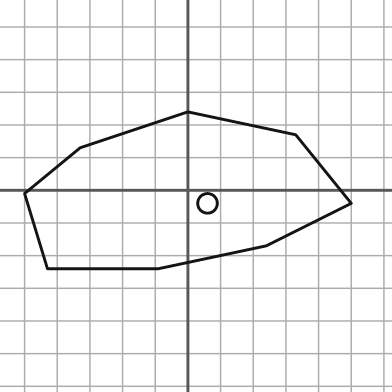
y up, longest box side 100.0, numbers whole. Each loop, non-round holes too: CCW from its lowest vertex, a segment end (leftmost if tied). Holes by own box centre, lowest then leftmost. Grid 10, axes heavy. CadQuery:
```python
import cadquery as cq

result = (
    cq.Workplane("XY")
    .moveTo(-43.0, -24.0)
    .lineTo(-9.0, -24.0)
    .lineTo(24.0, -17.0)
    .lineTo(50.0, -4.0)
    .lineTo(33.0, 17.0)
    .lineTo(0.0, 24.0)
    .lineTo(-33.0, 13.0)
    .lineTo(-50.0, -1.0)
    .close()
    .moveTo(6.0, -4.0)
    .circle(3.0)
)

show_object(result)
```